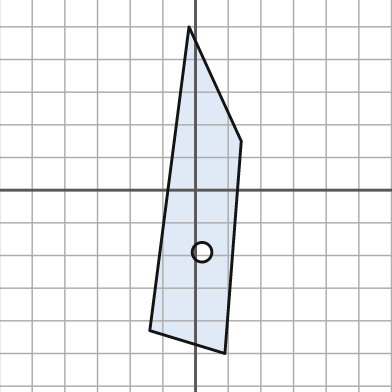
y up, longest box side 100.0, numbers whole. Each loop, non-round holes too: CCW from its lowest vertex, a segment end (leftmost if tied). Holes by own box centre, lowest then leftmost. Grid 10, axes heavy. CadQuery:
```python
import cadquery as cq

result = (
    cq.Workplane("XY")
    .moveTo(9.0, -50.0)
    .lineTo(14.0, 15.0)
    .lineTo(-2.0, 50.0)
    .lineTo(-14.0, -43.0)
    .close()
    .moveTo(2.0, -19.0)
    .circle(3.0)
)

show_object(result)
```